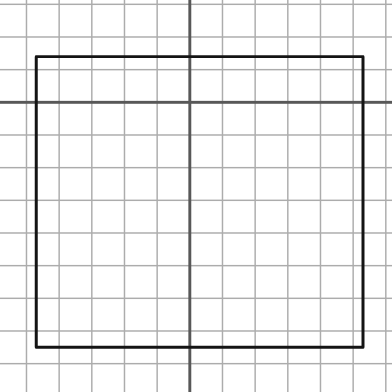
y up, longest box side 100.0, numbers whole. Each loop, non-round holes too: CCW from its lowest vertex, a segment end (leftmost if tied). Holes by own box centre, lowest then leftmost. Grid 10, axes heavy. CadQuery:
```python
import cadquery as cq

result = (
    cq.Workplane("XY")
    .moveTo(-47.0, -75.0)
    .lineTo(53.0, -75.0)
    .lineTo(53.0, 14.0)
    .lineTo(-47.0, 14.0)
    .close()
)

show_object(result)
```